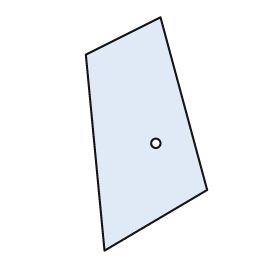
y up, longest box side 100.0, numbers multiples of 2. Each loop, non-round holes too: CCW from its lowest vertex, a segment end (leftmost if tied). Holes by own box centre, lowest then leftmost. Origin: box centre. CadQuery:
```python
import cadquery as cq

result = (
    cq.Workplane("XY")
    .moveTo(-18.0, -50.0)
    .lineTo(26.0, -24.0)
    .lineTo(6.0, 50.0)
    .lineTo(-26.0, 34.0)
    .close()
    .moveTo(4.0, -4.0)
    .circle(2.0)
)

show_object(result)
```